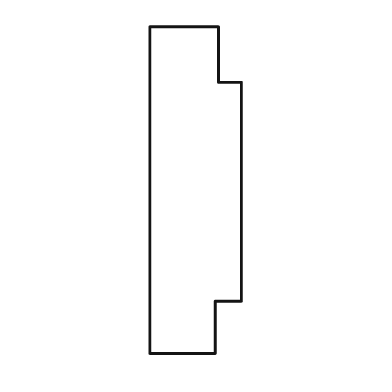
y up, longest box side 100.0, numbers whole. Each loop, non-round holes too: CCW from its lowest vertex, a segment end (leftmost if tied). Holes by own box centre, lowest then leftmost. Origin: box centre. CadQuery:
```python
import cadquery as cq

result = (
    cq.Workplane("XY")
    .moveTo(-14.0, -50.0)
    .lineTo(6.0, -50.0)
    .lineTo(6.0, -34.0)
    .lineTo(14.0, -34.0)
    .lineTo(14.0, 33.0)
    .lineTo(7.0, 33.0)
    .lineTo(7.0, 50.0)
    .lineTo(-14.0, 50.0)
    .close()
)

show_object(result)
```